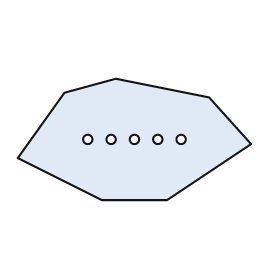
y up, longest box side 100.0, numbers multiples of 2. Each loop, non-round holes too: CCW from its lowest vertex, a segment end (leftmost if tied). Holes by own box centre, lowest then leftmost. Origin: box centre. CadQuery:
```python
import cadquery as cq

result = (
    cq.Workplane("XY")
    .moveTo(-14.0, -26.0)
    .lineTo(14.0, -26.0)
    .lineTo(50.0, -2.0)
    .lineTo(32.0, 18.0)
    .lineTo(-8.0, 26.0)
    .lineTo(-30.0, 20.0)
    .lineTo(-50.0, -8.0)
    .close()
    .moveTo(-20.0, 0.0)
    .circle(2.0)
    .moveTo(-10.0, 0.0)
    .circle(2.0)
    .moveTo(0.0, 0.0)
    .circle(2.0)
    .moveTo(10.0, 0.0)
    .circle(2.0)
    .moveTo(20.0, 0.0)
    .circle(2.0)
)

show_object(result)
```